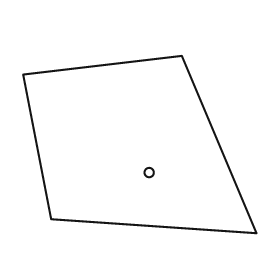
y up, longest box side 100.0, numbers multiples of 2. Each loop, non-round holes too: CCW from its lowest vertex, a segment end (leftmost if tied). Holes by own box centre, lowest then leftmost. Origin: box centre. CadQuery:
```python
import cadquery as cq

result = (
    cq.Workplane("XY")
    .moveTo(50.0, -38.0)
    .lineTo(18.0, 38.0)
    .lineTo(-50.0, 30.0)
    .lineTo(-38.0, -32.0)
    .close()
    .moveTo(4.0, -12.0)
    .circle(2.0)
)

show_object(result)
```